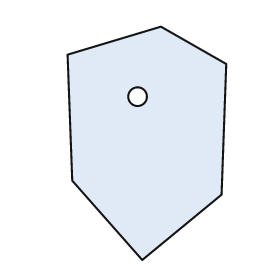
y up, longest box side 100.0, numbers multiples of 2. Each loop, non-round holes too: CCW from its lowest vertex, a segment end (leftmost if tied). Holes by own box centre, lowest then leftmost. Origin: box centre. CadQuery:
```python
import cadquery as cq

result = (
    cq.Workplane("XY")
    .moveTo(-2.0, -50.0)
    .lineTo(32.0, -22.0)
    .lineTo(34.0, 34.0)
    .lineTo(6.0, 50.0)
    .lineTo(-34.0, 38.0)
    .lineTo(-32.0, -16.0)
    .close()
    .moveTo(-4.0, 20.0)
    .circle(4.0)
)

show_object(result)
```